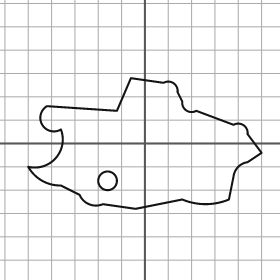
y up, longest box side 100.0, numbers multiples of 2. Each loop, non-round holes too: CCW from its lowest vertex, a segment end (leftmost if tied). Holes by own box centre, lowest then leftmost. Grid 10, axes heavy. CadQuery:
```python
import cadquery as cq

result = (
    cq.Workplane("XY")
    .moveTo(-4.0, -28.0)
    .lineTo(16.0, -24.0)
    .threePointArc((26.0, -26.0), (36.0, -24.0))
    .lineTo(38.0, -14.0)
    .threePointArc((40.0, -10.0), (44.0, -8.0))
    .lineTo(50.0, -4.0)
    .lineTo(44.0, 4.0)
    .threePointArc((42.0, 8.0), (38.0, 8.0))
    .lineTo(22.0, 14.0)
    .threePointArc((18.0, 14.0), (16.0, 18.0))
    .lineTo(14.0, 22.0)
    .threePointArc((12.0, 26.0), (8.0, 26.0))
    .lineTo(-6.0, 28.0)
    .lineTo(-12.0, 14.0)
    .lineTo(-42.0, 16.0)
    .threePointArc((-44.0, 8.0), (-36.0, 6.0))
    .threePointArc((-38.0, -6.0), (-50.0, -10.0))
    .threePointArc((-44.0, -16.0), (-36.0, -18.0))
    .lineTo(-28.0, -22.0)
    .threePointArc((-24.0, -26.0), (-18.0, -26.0))
    .close()
    .moveTo(-16.0, -16.0)
    .circle(4.0)
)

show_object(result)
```